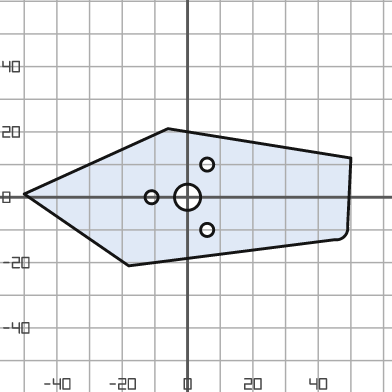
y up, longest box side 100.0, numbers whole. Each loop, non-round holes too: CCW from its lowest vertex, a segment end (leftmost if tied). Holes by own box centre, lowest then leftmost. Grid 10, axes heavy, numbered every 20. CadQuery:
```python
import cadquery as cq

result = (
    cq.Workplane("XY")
    .moveTo(-18.0, -21.0)
    .lineTo(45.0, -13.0)
    .threePointArc((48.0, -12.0), (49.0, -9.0))
    .lineTo(50.0, 12.0)
    .lineTo(-6.0, 21.0)
    .lineTo(-50.0, 1.0)
    .close()
    .moveTo(6.0, -10.0)
    .circle(2.0)
    .moveTo(-11.0, 0.0)
    .circle(2.0)
    .moveTo(0.0, 0.0)
    .circle(4.0)
    .moveTo(6.0, 10.0)
    .circle(2.0)
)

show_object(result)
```